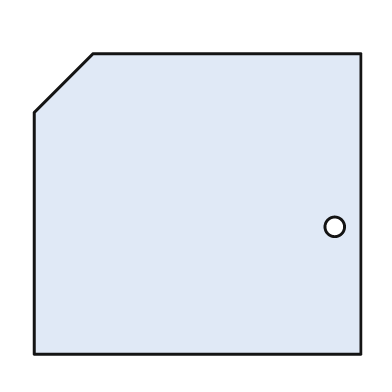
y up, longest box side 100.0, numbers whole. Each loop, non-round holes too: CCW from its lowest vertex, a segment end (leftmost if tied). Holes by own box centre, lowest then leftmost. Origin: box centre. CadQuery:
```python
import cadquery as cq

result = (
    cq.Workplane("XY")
    .moveTo(-50.0, -46.0)
    .lineTo(50.0, -46.0)
    .lineTo(50.0, 46.0)
    .lineTo(-32.0, 46.0)
    .lineTo(-50.0, 28.0)
    .close()
    .moveTo(42.0, -7.0)
    .circle(3.0)
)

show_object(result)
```